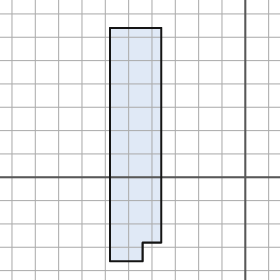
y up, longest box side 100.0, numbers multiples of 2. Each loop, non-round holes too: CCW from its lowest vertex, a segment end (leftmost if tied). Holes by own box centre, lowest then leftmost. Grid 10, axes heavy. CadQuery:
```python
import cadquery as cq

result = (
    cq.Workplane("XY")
    .moveTo(-58.0, -36.0)
    .lineTo(-44.0, -36.0)
    .lineTo(-44.0, -28.0)
    .lineTo(-36.0, -28.0)
    .lineTo(-36.0, 64.0)
    .lineTo(-58.0, 64.0)
    .close()
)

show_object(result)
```